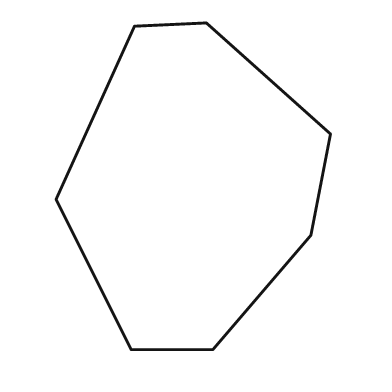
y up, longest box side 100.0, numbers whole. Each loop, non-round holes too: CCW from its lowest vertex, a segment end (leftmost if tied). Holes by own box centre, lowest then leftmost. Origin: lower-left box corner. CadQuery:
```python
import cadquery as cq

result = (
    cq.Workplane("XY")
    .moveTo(23.0, 0.0)
    .lineTo(48.0, 0.0)
    .lineTo(78.0, 35.0)
    .lineTo(84.0, 66.0)
    .lineTo(46.0, 100.0)
    .lineTo(24.0, 99.0)
    .lineTo(0.0, 46.0)
    .close()
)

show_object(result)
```